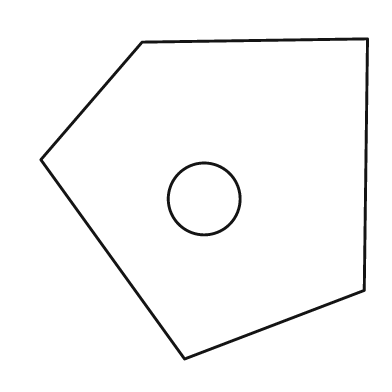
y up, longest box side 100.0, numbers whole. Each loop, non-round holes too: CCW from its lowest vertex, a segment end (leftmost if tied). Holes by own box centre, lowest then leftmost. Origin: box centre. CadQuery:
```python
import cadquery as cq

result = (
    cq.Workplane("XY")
    .moveTo(-6.0, -49.0)
    .lineTo(49.0, -28.0)
    .lineTo(50.0, 49.0)
    .lineTo(-19.0, 48.0)
    .lineTo(-50.0, 12.0)
    .close()
    .moveTo(0.0, 0.0)
    .circle(11.0)
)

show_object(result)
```